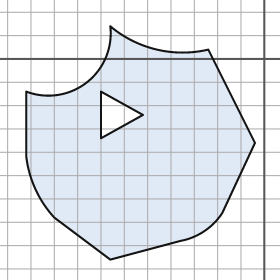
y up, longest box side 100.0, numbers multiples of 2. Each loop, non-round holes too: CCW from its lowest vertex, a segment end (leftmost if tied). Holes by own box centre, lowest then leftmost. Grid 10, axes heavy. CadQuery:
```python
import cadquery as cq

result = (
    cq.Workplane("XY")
    .moveTo(-66.0, -86.0)
    .lineTo(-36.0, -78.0)
    .threePointArc((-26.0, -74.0), (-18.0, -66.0))
    .lineTo(-4.0, -36.0)
    .lineTo(-24.0, 4.0)
    .threePointArc((-46.0, 4.0), (-66.0, 14.0))
    .threePointArc((-76.0, -10.0), (-102.0, -14.0))
    .lineTo(-102.0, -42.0)
    .threePointArc((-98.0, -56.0), (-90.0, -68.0))
    .close()
    .moveTo(-70.0, -34.0)
    .lineTo(-52.0, -24.0)
    .lineTo(-70.0, -14.0)
    .close()
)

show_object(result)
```